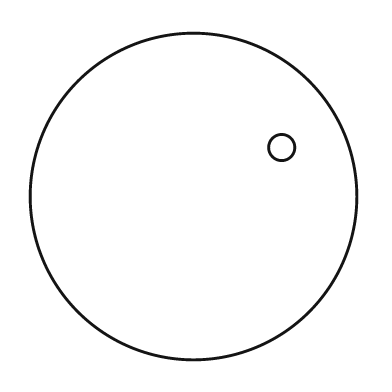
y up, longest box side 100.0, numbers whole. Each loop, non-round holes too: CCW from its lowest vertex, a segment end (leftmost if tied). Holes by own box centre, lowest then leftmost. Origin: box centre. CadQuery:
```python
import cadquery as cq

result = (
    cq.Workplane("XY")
    .moveTo(0.0, 0.0)
    .circle(50.0)
    .moveTo(27.0, 15.0)
    .circle(4.0)
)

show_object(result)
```